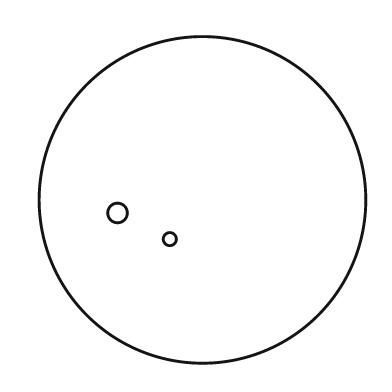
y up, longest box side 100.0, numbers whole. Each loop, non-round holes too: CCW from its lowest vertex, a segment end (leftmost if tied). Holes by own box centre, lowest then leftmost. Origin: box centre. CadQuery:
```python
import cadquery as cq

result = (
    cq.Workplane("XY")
    .moveTo(0.0, 0.0)
    .circle(50.0)
    .moveTo(-10.0, -12.0)
    .circle(2.0)
    .moveTo(-26.0, -4.0)
    .circle(3.0)
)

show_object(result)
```